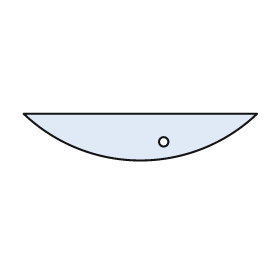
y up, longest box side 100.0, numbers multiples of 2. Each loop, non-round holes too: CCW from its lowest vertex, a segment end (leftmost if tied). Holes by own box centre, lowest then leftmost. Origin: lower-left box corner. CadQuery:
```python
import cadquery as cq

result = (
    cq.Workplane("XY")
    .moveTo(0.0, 20.0)
    .threePointArc((50.0, 0.0), (100.0, 20.0))
    .close()
    .moveTo(60.0, 8.0)
    .circle(2.0)
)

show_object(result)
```